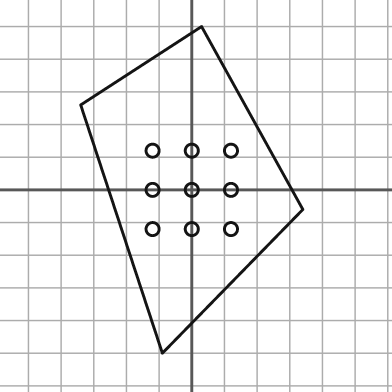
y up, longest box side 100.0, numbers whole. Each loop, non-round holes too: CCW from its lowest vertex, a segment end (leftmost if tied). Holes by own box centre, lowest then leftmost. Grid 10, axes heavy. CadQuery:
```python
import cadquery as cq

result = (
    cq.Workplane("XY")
    .moveTo(-9.0, -50.0)
    .lineTo(34.0, -6.0)
    .lineTo(3.0, 50.0)
    .lineTo(-34.0, 26.0)
    .close()
    .moveTo(-12.0, -12.0)
    .circle(2.0)
    .moveTo(0.0, -12.0)
    .circle(2.0)
    .moveTo(12.0, -12.0)
    .circle(2.0)
    .moveTo(-12.0, 0.0)
    .circle(2.0)
    .moveTo(0.0, 0.0)
    .circle(2.0)
    .moveTo(12.0, 0.0)
    .circle(2.0)
    .moveTo(-12.0, 12.0)
    .circle(2.0)
    .moveTo(0.0, 12.0)
    .circle(2.0)
    .moveTo(12.0, 12.0)
    .circle(2.0)
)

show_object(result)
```